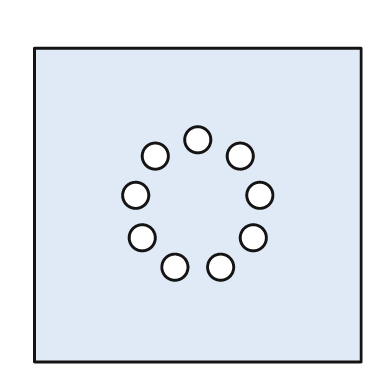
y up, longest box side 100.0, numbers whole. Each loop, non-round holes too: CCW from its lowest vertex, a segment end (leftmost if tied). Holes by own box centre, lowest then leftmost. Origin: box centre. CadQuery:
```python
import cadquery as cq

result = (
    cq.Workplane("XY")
    .moveTo(-50.0, -48.0)
    .lineTo(50.0, -48.0)
    .lineTo(50.0, 48.0)
    .lineTo(-50.0, 48.0)
    .close()
    .moveTo(-7.0, -19.0)
    .circle(4.0)
    .moveTo(7.0, -19.0)
    .circle(4.0)
    .moveTo(-17.0, -10.0)
    .circle(4.0)
    .moveTo(17.0, -10.0)
    .circle(4.0)
    .moveTo(-19.0, 3.0)
    .circle(4.0)
    .moveTo(19.0, 3.0)
    .circle(4.0)
    .moveTo(-13.0, 15.0)
    .circle(4.0)
    .moveTo(13.0, 15.0)
    .circle(4.0)
    .moveTo(0.0, 20.0)
    .circle(4.0)
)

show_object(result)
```